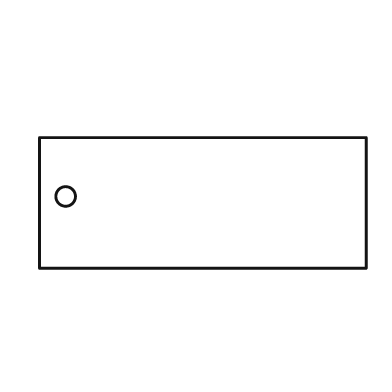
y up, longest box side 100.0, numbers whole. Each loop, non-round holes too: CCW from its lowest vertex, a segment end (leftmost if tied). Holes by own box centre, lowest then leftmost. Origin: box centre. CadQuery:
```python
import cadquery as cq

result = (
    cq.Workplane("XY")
    .moveTo(-50.0, -20.0)
    .lineTo(50.0, -20.0)
    .lineTo(50.0, 20.0)
    .lineTo(-50.0, 20.0)
    .close()
    .moveTo(-42.0, 2.0)
    .circle(3.0)
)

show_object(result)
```